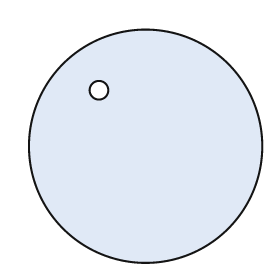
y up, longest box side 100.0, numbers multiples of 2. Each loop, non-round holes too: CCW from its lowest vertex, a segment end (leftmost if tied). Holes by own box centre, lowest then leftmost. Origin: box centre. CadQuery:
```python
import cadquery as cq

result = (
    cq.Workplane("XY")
    .moveTo(0.0, 0.0)
    .circle(50.0)
    .moveTo(-20.0, 24.0)
    .circle(4.0)
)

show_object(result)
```